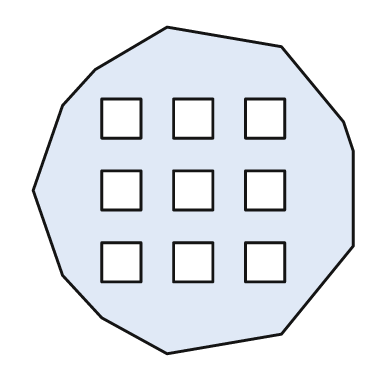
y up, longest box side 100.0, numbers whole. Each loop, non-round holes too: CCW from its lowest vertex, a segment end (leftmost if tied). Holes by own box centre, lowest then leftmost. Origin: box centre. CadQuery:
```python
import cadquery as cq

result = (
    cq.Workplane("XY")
    .moveTo(-8.0, -50.0)
    .lineTo(27.0, -44.0)
    .lineTo(49.0, -17.0)
    .lineTo(49.0, 12.0)
    .lineTo(46.0, 21.0)
    .lineTo(27.0, 44.0)
    .lineTo(-8.0, 50.0)
    .lineTo(-30.0, 37.0)
    .lineTo(-40.0, 26.0)
    .lineTo(-49.0, 0.0)
    .lineTo(-40.0, -26.0)
    .lineTo(-28.0, -39.0)
    .close()
    .moveTo(-28.0, -28.0)
    .lineTo(-16.0, -28.0)
    .lineTo(-16.0, -16.0)
    .lineTo(-28.0, -16.0)
    .close()
    .moveTo(-6.0, -28.0)
    .lineTo(6.0, -28.0)
    .lineTo(6.0, -16.0)
    .lineTo(-6.0, -16.0)
    .close()
    .moveTo(16.0, -28.0)
    .lineTo(28.0, -28.0)
    .lineTo(28.0, -16.0)
    .lineTo(16.0, -16.0)
    .close()
    .moveTo(-28.0, -6.0)
    .lineTo(-16.0, -6.0)
    .lineTo(-16.0, 6.0)
    .lineTo(-28.0, 6.0)
    .close()
    .moveTo(-6.0, -6.0)
    .lineTo(6.0, -6.0)
    .lineTo(6.0, 6.0)
    .lineTo(-6.0, 6.0)
    .close()
    .moveTo(16.0, -6.0)
    .lineTo(28.0, -6.0)
    .lineTo(28.0, 6.0)
    .lineTo(16.0, 6.0)
    .close()
    .moveTo(-28.0, 16.0)
    .lineTo(-16.0, 16.0)
    .lineTo(-16.0, 28.0)
    .lineTo(-28.0, 28.0)
    .close()
    .moveTo(-6.0, 16.0)
    .lineTo(6.0, 16.0)
    .lineTo(6.0, 28.0)
    .lineTo(-6.0, 28.0)
    .close()
    .moveTo(16.0, 16.0)
    .lineTo(28.0, 16.0)
    .lineTo(28.0, 28.0)
    .lineTo(16.0, 28.0)
    .close()
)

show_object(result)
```